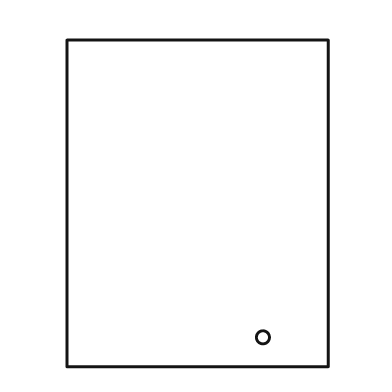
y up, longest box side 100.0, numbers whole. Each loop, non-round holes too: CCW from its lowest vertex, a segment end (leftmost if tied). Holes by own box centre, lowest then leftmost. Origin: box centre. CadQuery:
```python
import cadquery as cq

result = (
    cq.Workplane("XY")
    .moveTo(-40.0, -50.0)
    .lineTo(40.0, -50.0)
    .lineTo(40.0, 50.0)
    .lineTo(-40.0, 50.0)
    .close()
    .moveTo(20.0, -41.0)
    .circle(2.0)
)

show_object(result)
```